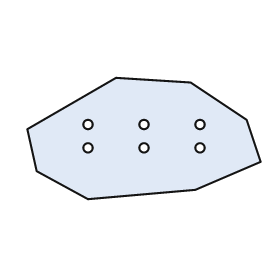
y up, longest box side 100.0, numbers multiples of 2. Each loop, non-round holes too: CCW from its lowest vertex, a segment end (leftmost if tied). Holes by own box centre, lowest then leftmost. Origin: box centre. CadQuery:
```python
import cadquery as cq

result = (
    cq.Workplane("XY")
    .moveTo(-24.0, -26.0)
    .lineTo(22.0, -22.0)
    .lineTo(50.0, -10.0)
    .lineTo(44.0, 8.0)
    .lineTo(20.0, 24.0)
    .lineTo(-12.0, 26.0)
    .lineTo(-50.0, 4.0)
    .lineTo(-46.0, -14.0)
    .close()
    .moveTo(-24.0, -4.0)
    .circle(2.0)
    .moveTo(0.0, -4.0)
    .circle(2.0)
    .moveTo(24.0, -4.0)
    .circle(2.0)
    .moveTo(-24.0, 6.0)
    .circle(2.0)
    .moveTo(0.0, 6.0)
    .circle(2.0)
    .moveTo(24.0, 6.0)
    .circle(2.0)
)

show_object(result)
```